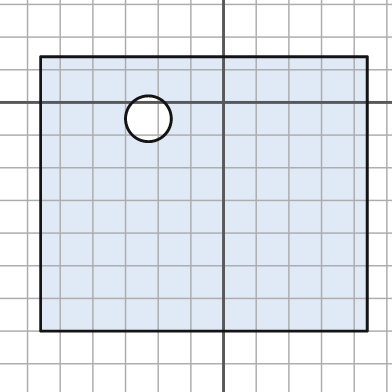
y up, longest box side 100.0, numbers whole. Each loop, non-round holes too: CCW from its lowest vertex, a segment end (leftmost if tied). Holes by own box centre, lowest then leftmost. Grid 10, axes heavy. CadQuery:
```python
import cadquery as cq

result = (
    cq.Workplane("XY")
    .moveTo(-56.0, -70.0)
    .lineTo(44.0, -70.0)
    .lineTo(44.0, 14.0)
    .lineTo(-56.0, 14.0)
    .close()
    .moveTo(-23.0, -5.0)
    .circle(7.0)
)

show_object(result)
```